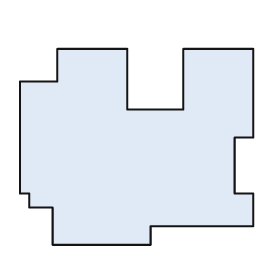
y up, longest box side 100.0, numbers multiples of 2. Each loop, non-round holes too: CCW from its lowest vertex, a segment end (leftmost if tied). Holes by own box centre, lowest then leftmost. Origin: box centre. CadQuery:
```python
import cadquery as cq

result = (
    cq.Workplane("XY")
    .moveTo(-36.0, -42.0)
    .lineTo(6.0, -42.0)
    .lineTo(6.0, -34.0)
    .lineTo(50.0, -34.0)
    .lineTo(50.0, -20.0)
    .lineTo(42.0, -20.0)
    .lineTo(42.0, 4.0)
    .lineTo(50.0, 4.0)
    .lineTo(50.0, 42.0)
    .lineTo(20.0, 42.0)
    .lineTo(20.0, 16.0)
    .lineTo(-4.0, 16.0)
    .lineTo(-4.0, 42.0)
    .lineTo(-34.0, 42.0)
    .lineTo(-34.0, 28.0)
    .lineTo(-50.0, 28.0)
    .lineTo(-50.0, -20.0)
    .lineTo(-46.0, -20.0)
    .lineTo(-46.0, -26.0)
    .lineTo(-36.0, -26.0)
    .close()
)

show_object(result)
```